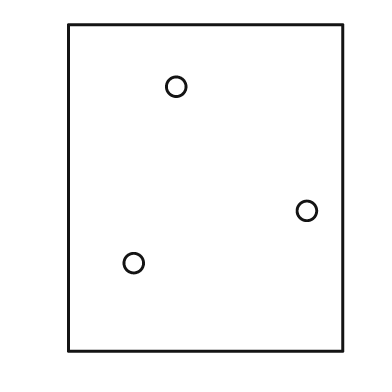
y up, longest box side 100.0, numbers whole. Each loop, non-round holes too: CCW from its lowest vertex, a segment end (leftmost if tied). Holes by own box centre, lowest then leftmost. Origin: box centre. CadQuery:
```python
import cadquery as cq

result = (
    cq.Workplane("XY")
    .moveTo(-42.0, -50.0)
    .lineTo(42.0, -50.0)
    .lineTo(42.0, 50.0)
    .lineTo(-42.0, 50.0)
    .close()
    .moveTo(-22.0, -23.0)
    .circle(3.0)
    .moveTo(31.0, -7.0)
    .circle(3.0)
    .moveTo(-9.0, 31.0)
    .circle(3.0)
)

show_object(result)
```